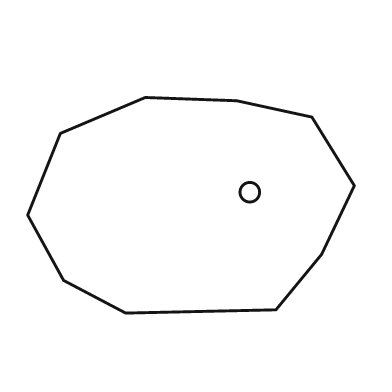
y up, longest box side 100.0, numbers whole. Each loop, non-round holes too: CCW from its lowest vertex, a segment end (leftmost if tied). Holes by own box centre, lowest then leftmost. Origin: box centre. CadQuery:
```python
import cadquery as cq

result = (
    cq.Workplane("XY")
    .moveTo(-20.0, -33.0)
    .lineTo(26.0, -32.0)
    .lineTo(40.0, -15.0)
    .lineTo(50.0, 6.0)
    .lineTo(37.0, 27.0)
    .lineTo(14.0, 32.0)
    .lineTo(-14.0, 33.0)
    .lineTo(-40.0, 22.0)
    .lineTo(-50.0, -3.0)
    .lineTo(-39.0, -23.0)
    .close()
    .moveTo(18.0, 4.0)
    .circle(3.0)
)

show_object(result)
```